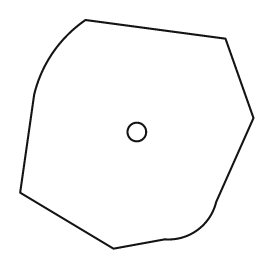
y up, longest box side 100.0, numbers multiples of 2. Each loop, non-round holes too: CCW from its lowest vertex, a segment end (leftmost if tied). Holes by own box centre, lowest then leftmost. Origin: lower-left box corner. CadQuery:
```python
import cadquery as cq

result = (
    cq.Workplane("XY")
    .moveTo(40.0, 0.0)
    .lineTo(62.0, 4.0)
    .threePointArc((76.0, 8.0), (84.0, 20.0))
    .lineTo(100.0, 56.0)
    .lineTo(88.0, 90.0)
    .lineTo(28.0, 98.0)
    .threePointArc((14.0, 84.0), (6.0, 66.0))
    .lineTo(0.0, 24.0)
    .close()
    .moveTo(50.0, 50.0)
    .circle(4.0)
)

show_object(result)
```